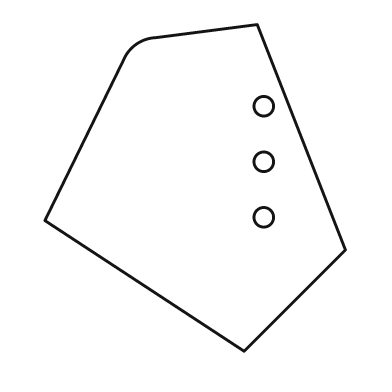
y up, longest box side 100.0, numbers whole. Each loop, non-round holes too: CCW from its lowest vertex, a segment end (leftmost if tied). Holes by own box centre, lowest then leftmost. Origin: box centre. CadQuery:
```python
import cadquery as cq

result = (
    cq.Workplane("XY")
    .moveTo(15.0, -50.0)
    .lineTo(46.0, -19.0)
    .lineTo(19.0, 50.0)
    .lineTo(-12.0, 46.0)
    .threePointArc((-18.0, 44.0), (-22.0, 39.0))
    .lineTo(-46.0, -10.0)
    .close()
    .moveTo(21.0, -9.0)
    .circle(3.0)
    .moveTo(21.0, 8.0)
    .circle(3.0)
    .moveTo(21.0, 25.0)
    .circle(3.0)
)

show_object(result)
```